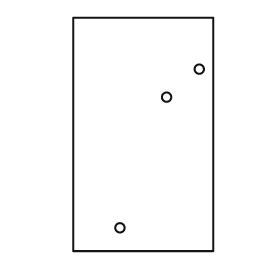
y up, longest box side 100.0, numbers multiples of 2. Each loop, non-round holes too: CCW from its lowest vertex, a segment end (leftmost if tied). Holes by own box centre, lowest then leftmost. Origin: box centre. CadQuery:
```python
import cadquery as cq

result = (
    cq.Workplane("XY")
    .moveTo(-30.0, -50.0)
    .lineTo(30.0, -50.0)
    .lineTo(30.0, 50.0)
    .lineTo(-30.0, 50.0)
    .close()
    .moveTo(-10.0, -40.0)
    .circle(2.0)
    .moveTo(10.0, 16.0)
    .circle(2.0)
    .moveTo(24.0, 28.0)
    .circle(2.0)
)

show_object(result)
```